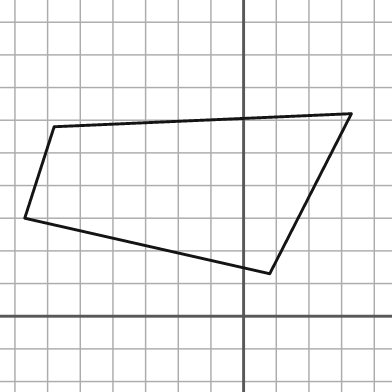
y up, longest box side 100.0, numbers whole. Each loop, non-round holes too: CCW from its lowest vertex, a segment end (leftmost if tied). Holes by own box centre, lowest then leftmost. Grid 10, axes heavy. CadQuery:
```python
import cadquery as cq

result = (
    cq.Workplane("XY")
    .moveTo(8.0, 13.0)
    .lineTo(33.0, 62.0)
    .lineTo(-58.0, 58.0)
    .lineTo(-67.0, 30.0)
    .close()
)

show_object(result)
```